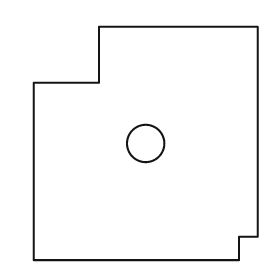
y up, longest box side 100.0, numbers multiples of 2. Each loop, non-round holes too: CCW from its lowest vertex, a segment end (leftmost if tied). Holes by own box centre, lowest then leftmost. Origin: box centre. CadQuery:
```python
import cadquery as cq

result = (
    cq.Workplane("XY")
    .moveTo(-48.0, -50.0)
    .lineTo(40.0, -50.0)
    .lineTo(40.0, -40.0)
    .lineTo(48.0, -40.0)
    .lineTo(48.0, 50.0)
    .lineTo(-20.0, 50.0)
    .lineTo(-20.0, 26.0)
    .lineTo(-48.0, 26.0)
    .close()
    .moveTo(0.0, 0.0)
    .circle(8.0)
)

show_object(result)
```